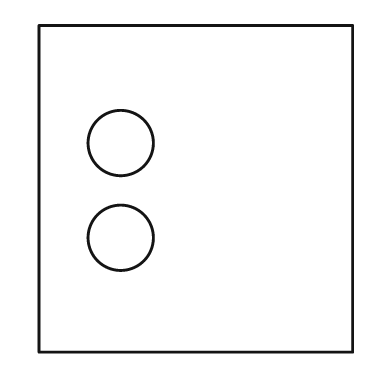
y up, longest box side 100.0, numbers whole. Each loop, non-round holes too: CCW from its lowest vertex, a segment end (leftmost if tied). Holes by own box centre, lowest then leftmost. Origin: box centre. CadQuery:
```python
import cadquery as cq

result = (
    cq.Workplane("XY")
    .moveTo(-48.0, -50.0)
    .lineTo(48.0, -50.0)
    .lineTo(48.0, 50.0)
    .lineTo(-48.0, 50.0)
    .close()
    .moveTo(-23.0, -15.0)
    .circle(10.0)
    .moveTo(-23.0, 14.0)
    .circle(10.0)
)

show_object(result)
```